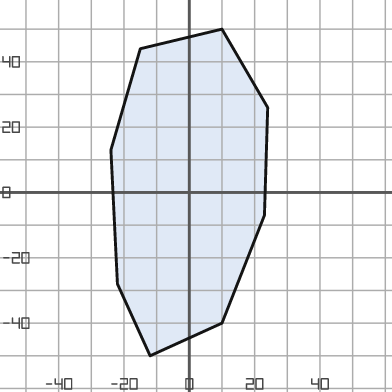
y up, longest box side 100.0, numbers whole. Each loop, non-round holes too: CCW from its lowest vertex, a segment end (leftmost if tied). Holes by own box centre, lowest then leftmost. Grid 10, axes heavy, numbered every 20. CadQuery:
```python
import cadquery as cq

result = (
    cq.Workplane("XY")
    .moveTo(-12.0, -50.0)
    .lineTo(10.0, -40.0)
    .lineTo(23.0, -7.0)
    .lineTo(24.0, 26.0)
    .lineTo(10.0, 50.0)
    .lineTo(-15.0, 44.0)
    .lineTo(-24.0, 13.0)
    .lineTo(-22.0, -28.0)
    .close()
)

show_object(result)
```